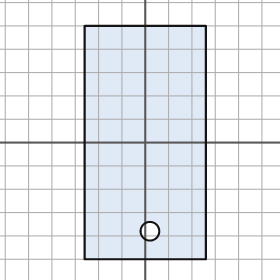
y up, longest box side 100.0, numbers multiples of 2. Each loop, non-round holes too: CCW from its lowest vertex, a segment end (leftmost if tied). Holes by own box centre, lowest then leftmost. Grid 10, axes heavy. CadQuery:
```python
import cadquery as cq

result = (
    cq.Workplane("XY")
    .moveTo(-26.0, -50.0)
    .lineTo(26.0, -50.0)
    .lineTo(26.0, 50.0)
    .lineTo(-26.0, 50.0)
    .close()
    .moveTo(2.0, -38.0)
    .circle(4.0)
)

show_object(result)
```